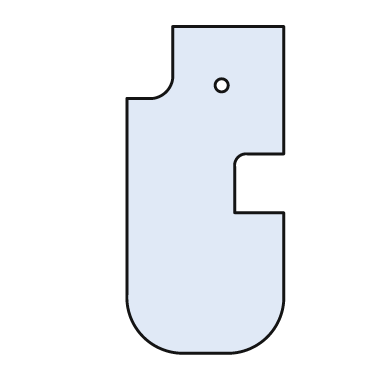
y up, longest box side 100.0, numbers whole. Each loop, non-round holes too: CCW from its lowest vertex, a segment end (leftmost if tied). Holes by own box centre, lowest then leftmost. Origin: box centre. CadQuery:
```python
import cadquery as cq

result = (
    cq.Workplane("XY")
    .moveTo(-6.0, -50.0)
    .lineTo(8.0, -50.0)
    .threePointArc((19.0, -45.0), (24.0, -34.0))
    .lineTo(24.0, -7.0)
    .lineTo(9.0, -7.0)
    .lineTo(9.0, 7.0)
    .threePointArc((10.0, 10.0), (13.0, 11.0))
    .lineTo(24.0, 11.0)
    .lineTo(24.0, 50.0)
    .lineTo(-10.0, 50.0)
    .lineTo(-10.0, 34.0)
    .threePointArc((-12.0, 30.0), (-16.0, 28.0))
    .lineTo(-24.0, 28.0)
    .lineTo(-24.0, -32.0)
    .threePointArc((-19.0, -45.0), (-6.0, -50.0))
    .close()
    .moveTo(5.0, 32.0)
    .circle(2.0)
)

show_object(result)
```